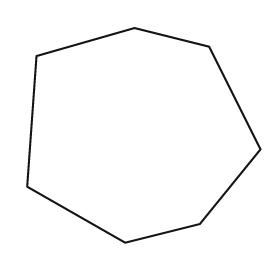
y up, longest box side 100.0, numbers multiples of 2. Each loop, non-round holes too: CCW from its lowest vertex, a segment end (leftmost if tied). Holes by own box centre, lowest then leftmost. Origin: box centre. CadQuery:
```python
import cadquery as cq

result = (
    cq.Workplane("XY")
    .moveTo(-8.0, -46.0)
    .lineTo(24.0, -38.0)
    .lineTo(50.0, -6.0)
    .lineTo(28.0, 38.0)
    .lineTo(-4.0, 46.0)
    .lineTo(-46.0, 34.0)
    .lineTo(-50.0, -22.0)
    .close()
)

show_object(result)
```